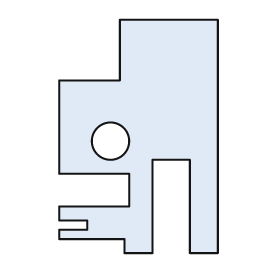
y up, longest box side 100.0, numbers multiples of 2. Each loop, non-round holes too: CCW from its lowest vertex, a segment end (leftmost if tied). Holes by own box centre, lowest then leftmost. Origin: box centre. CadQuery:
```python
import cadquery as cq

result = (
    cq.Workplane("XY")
    .moveTo(-6.0, -50.0)
    .lineTo(6.0, -50.0)
    .lineTo(6.0, -10.0)
    .lineTo(22.0, -10.0)
    .lineTo(22.0, -50.0)
    .lineTo(34.0, -50.0)
    .lineTo(34.0, 50.0)
    .lineTo(-8.0, 50.0)
    .lineTo(-8.0, 24.0)
    .lineTo(-34.0, 24.0)
    .lineTo(-34.0, -16.0)
    .lineTo(-4.0, -16.0)
    .lineTo(-4.0, -30.0)
    .lineTo(-34.0, -30.0)
    .lineTo(-34.0, -36.0)
    .lineTo(-22.0, -36.0)
    .lineTo(-22.0, -40.0)
    .lineTo(-34.0, -40.0)
    .lineTo(-34.0, -44.0)
    .lineTo(-6.0, -44.0)
    .close()
    .moveTo(-12.0, -2.0)
    .circle(8.0)
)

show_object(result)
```